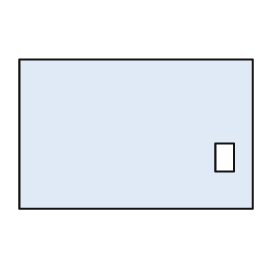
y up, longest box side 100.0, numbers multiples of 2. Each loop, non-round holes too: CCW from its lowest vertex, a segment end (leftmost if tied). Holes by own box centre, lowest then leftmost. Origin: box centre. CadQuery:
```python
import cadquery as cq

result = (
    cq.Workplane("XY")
    .moveTo(-50.0, -32.0)
    .lineTo(50.0, -32.0)
    .lineTo(50.0, 32.0)
    .lineTo(-50.0, 32.0)
    .close()
    .moveTo(34.0, -16.0)
    .lineTo(42.0, -16.0)
    .lineTo(42.0, -4.0)
    .lineTo(34.0, -4.0)
    .close()
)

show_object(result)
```